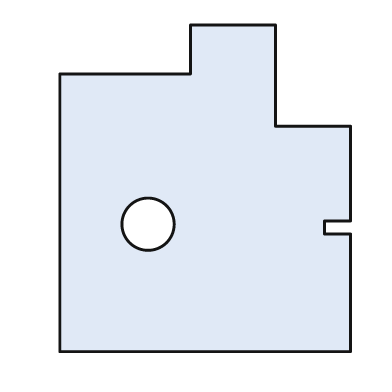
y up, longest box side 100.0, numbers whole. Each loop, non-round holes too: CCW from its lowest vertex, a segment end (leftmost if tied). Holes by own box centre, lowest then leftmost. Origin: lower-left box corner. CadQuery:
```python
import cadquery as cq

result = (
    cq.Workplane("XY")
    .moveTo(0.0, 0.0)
    .lineTo(89.0, 0.0)
    .lineTo(89.0, 36.0)
    .lineTo(81.0, 36.0)
    .lineTo(81.0, 40.0)
    .lineTo(89.0, 40.0)
    .lineTo(89.0, 69.0)
    .lineTo(66.0, 69.0)
    .lineTo(66.0, 100.0)
    .lineTo(40.0, 100.0)
    .lineTo(40.0, 85.0)
    .lineTo(0.0, 85.0)
    .close()
    .moveTo(27.0, 39.0)
    .circle(8.0)
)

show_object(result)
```